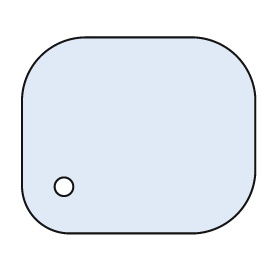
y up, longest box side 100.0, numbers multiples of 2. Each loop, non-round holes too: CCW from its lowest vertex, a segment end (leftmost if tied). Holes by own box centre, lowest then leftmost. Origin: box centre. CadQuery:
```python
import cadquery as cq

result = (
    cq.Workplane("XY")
    .moveTo(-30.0, -42.0)
    .lineTo(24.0, -42.0)
    .threePointArc((42.0, -34.0), (50.0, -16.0))
    .lineTo(50.0, 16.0)
    .threePointArc((42.0, 34.0), (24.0, 42.0))
    .lineTo(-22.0, 42.0)
    .threePointArc((-42.0, 34.0), (-50.0, 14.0))
    .lineTo(-50.0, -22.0)
    .threePointArc((-44.0, -36.0), (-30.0, -42.0))
    .close()
    .moveTo(-32.0, -22.0)
    .circle(4.0)
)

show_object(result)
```